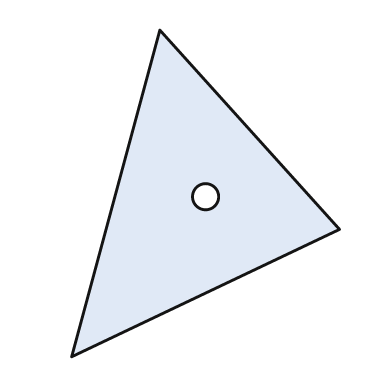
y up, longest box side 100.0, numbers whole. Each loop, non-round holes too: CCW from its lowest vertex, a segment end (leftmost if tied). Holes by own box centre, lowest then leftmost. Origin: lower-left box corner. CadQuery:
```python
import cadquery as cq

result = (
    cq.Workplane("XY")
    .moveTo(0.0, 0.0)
    .lineTo(82.0, 39.0)
    .lineTo(27.0, 100.0)
    .close()
    .moveTo(41.0, 49.0)
    .circle(4.0)
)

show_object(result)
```